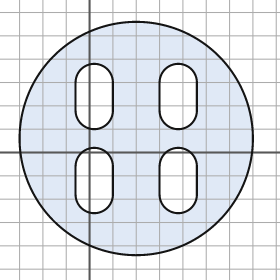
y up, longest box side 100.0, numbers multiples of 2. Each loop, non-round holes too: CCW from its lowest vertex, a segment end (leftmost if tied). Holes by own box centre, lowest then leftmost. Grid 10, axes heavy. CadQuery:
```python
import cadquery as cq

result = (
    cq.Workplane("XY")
    .moveTo(20.0, 6.0)
    .circle(50.0)
    .moveTo(-6.0, -18.0)
    .threePointArc((2.0, -26.0), (10.0, -18.0))
    .lineTo(10.0, -6.0)
    .threePointArc((2.0, 2.0), (-6.0, -6.0))
    .close()
    .moveTo(30.0, -18.0)
    .threePointArc((38.0, -26.0), (46.0, -18.0))
    .lineTo(46.0, -6.0)
    .threePointArc((38.0, 2.0), (30.0, -6.0))
    .close()
    .moveTo(-6.0, 18.0)
    .threePointArc((2.0, 10.0), (10.0, 18.0))
    .lineTo(10.0, 30.0)
    .threePointArc((2.0, 38.0), (-6.0, 30.0))
    .close()
    .moveTo(30.0, 18.0)
    .threePointArc((38.0, 10.0), (46.0, 18.0))
    .lineTo(46.0, 30.0)
    .threePointArc((38.0, 38.0), (30.0, 30.0))
    .close()
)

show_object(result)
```